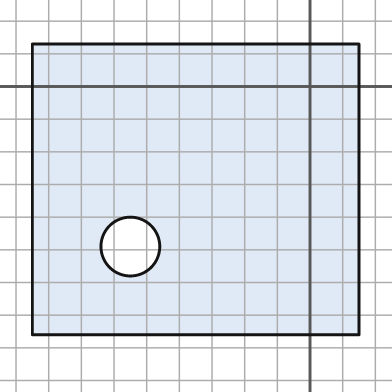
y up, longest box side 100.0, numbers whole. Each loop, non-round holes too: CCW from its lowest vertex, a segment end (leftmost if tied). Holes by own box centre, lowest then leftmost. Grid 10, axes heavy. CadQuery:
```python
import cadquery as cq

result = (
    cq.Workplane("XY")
    .moveTo(-85.0, -76.0)
    .lineTo(15.0, -76.0)
    .lineTo(15.0, 13.0)
    .lineTo(-85.0, 13.0)
    .close()
    .moveTo(-55.0, -49.0)
    .circle(9.0)
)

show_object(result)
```